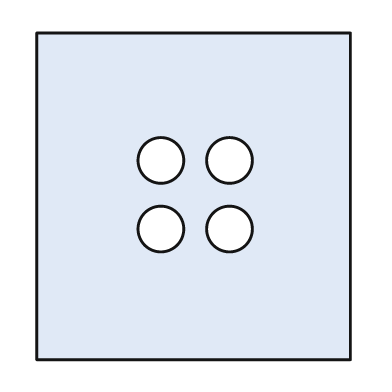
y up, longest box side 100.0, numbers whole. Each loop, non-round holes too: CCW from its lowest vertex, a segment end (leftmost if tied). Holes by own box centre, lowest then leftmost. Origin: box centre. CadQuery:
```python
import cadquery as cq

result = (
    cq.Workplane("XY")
    .moveTo(-48.0, -50.0)
    .lineTo(48.0, -50.0)
    .lineTo(48.0, 50.0)
    .lineTo(-48.0, 50.0)
    .close()
    .moveTo(-10.0, -10.0)
    .circle(7.0)
    .moveTo(11.0, -10.0)
    .circle(7.0)
    .moveTo(-10.0, 11.0)
    .circle(7.0)
    .moveTo(11.0, 11.0)
    .circle(7.0)
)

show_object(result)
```